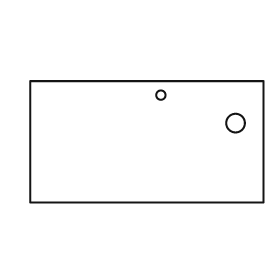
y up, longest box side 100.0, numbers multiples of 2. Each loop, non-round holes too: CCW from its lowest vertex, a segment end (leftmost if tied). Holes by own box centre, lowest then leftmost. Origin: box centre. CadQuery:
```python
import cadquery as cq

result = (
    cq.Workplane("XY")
    .moveTo(-50.0, -26.0)
    .lineTo(50.0, -26.0)
    .lineTo(50.0, 26.0)
    .lineTo(-50.0, 26.0)
    .close()
    .moveTo(38.0, 8.0)
    .circle(4.0)
    .moveTo(6.0, 20.0)
    .circle(2.0)
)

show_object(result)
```